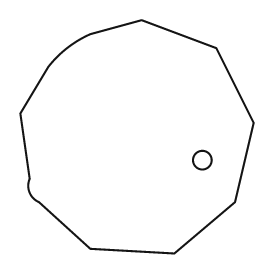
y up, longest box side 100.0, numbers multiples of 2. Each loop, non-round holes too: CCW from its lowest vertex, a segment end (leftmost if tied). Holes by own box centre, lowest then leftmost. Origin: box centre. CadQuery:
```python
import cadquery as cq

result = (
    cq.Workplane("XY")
    .moveTo(16.0, -50.0)
    .lineTo(42.0, -28.0)
    .lineTo(50.0, 6.0)
    .lineTo(34.0, 38.0)
    .lineTo(2.0, 50.0)
    .lineTo(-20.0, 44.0)
    .threePointArc((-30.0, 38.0), (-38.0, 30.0))
    .lineTo(-50.0, 10.0)
    .lineTo(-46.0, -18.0)
    .threePointArc((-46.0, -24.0), (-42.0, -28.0))
    .lineTo(-20.0, -48.0)
    .close()
    .moveTo(28.0, -10.0)
    .circle(4.0)
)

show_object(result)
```